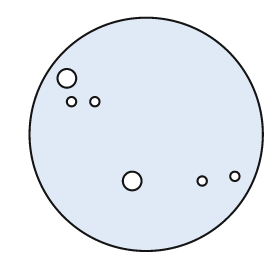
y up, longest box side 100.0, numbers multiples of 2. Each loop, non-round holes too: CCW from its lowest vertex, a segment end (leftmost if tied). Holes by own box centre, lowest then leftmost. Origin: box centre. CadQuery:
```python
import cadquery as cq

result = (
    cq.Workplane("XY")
    .moveTo(0.0, 0.0)
    .circle(50.0)
    .moveTo(-6.0, -20.0)
    .circle(4.0)
    .moveTo(24.0, -20.0)
    .circle(2.0)
    .moveTo(38.0, -18.0)
    .circle(2.0)
    .moveTo(-32.0, 14.0)
    .circle(2.0)
    .moveTo(-22.0, 14.0)
    .circle(2.0)
    .moveTo(-34.0, 24.0)
    .circle(4.0)
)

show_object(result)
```